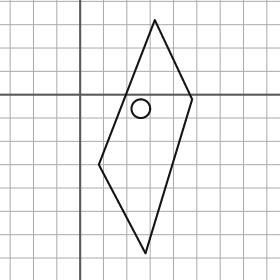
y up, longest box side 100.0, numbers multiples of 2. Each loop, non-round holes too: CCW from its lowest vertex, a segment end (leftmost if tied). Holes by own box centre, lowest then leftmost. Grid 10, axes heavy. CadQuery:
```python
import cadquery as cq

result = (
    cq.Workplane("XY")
    .moveTo(28.0, -68.0)
    .lineTo(48.0, -2.0)
    .lineTo(32.0, 32.0)
    .lineTo(8.0, -30.0)
    .close()
    .moveTo(26.0, -6.0)
    .circle(4.0)
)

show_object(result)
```